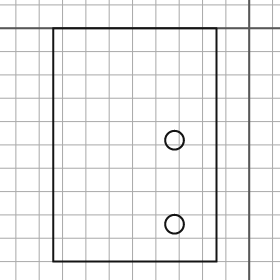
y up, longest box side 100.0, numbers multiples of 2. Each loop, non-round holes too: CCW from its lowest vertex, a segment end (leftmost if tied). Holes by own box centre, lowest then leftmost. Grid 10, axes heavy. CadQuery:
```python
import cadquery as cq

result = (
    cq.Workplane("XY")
    .moveTo(-84.0, -100.0)
    .lineTo(-14.0, -100.0)
    .lineTo(-14.0, 0.0)
    .lineTo(-84.0, 0.0)
    .close()
    .moveTo(-32.0, -84.0)
    .circle(4.0)
    .moveTo(-32.0, -48.0)
    .circle(4.0)
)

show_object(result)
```